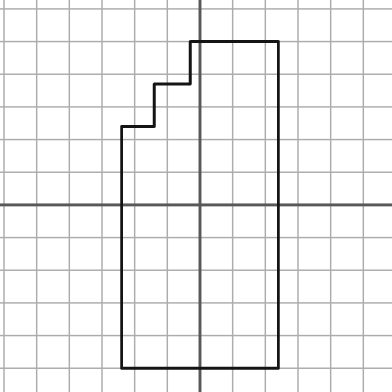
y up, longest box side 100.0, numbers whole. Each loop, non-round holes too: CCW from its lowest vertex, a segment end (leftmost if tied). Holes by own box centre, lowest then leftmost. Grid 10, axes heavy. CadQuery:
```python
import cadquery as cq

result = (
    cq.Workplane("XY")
    .moveTo(-24.0, -50.0)
    .lineTo(24.0, -50.0)
    .lineTo(24.0, 50.0)
    .lineTo(-3.0, 50.0)
    .lineTo(-3.0, 37.0)
    .lineTo(-14.0, 37.0)
    .lineTo(-14.0, 24.0)
    .lineTo(-24.0, 24.0)
    .close()
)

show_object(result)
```